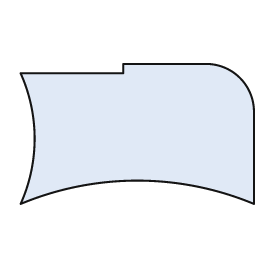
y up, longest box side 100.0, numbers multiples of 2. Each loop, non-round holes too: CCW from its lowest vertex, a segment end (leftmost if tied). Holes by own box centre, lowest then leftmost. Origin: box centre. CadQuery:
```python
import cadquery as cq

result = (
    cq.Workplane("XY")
    .moveTo(-50.0, -30.0)
    .threePointArc((0.0, -20.0), (50.0, -30.0))
    .lineTo(50.0, 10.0)
    .threePointArc((44.0, 24.0), (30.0, 30.0))
    .lineTo(-6.0, 30.0)
    .lineTo(-6.0, 26.0)
    .lineTo(-50.0, 26.0)
    .threePointArc((-44.0, -2.0), (-50.0, -30.0))
    .close()
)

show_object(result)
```